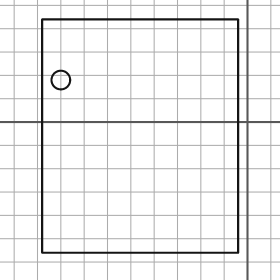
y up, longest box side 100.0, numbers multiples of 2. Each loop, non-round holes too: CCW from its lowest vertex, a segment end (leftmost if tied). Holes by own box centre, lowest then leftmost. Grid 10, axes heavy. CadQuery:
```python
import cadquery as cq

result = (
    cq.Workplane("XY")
    .moveTo(-88.0, -56.0)
    .lineTo(-4.0, -56.0)
    .lineTo(-4.0, 44.0)
    .lineTo(-88.0, 44.0)
    .close()
    .moveTo(-80.0, 18.0)
    .circle(4.0)
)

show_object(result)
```